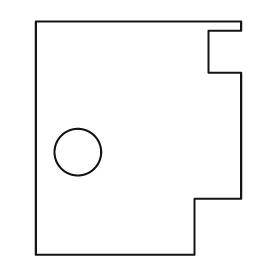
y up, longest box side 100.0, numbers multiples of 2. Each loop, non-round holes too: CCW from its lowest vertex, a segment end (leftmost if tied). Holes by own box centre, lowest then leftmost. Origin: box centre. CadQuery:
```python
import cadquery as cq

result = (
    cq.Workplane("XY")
    .moveTo(-44.0, -50.0)
    .lineTo(24.0, -50.0)
    .lineTo(24.0, -26.0)
    .lineTo(44.0, -26.0)
    .lineTo(44.0, 28.0)
    .lineTo(30.0, 28.0)
    .lineTo(30.0, 46.0)
    .lineTo(44.0, 46.0)
    .lineTo(44.0, 50.0)
    .lineTo(-44.0, 50.0)
    .close()
    .moveTo(-26.0, -6.0)
    .circle(10.0)
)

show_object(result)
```